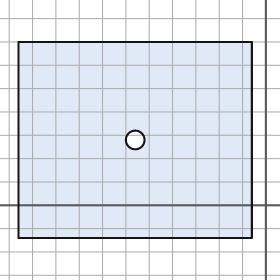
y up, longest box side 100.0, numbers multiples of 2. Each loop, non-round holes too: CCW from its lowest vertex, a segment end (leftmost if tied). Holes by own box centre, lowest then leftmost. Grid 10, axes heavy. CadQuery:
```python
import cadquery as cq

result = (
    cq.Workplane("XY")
    .moveTo(-106.0, -14.0)
    .lineTo(-6.0, -14.0)
    .lineTo(-6.0, 70.0)
    .lineTo(-106.0, 70.0)
    .close()
    .moveTo(-56.0, 28.0)
    .circle(4.0)
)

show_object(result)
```